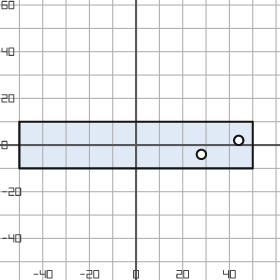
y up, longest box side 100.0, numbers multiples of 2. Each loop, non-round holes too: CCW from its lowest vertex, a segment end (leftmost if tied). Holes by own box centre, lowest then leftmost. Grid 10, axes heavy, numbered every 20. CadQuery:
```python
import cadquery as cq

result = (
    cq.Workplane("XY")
    .moveTo(-50.0, -10.0)
    .lineTo(50.0, -10.0)
    .lineTo(50.0, 10.0)
    .lineTo(-50.0, 10.0)
    .close()
    .moveTo(28.0, -4.0)
    .circle(2.0)
    .moveTo(44.0, 2.0)
    .circle(2.0)
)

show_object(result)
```